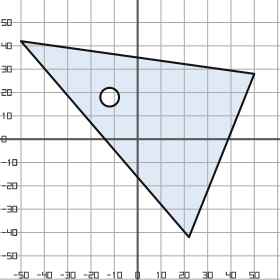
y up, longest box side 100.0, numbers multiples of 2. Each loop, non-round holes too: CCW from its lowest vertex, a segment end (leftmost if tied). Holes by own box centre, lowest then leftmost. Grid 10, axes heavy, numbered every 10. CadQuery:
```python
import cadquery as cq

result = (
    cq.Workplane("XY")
    .moveTo(22.0, -42.0)
    .lineTo(50.0, 28.0)
    .lineTo(-50.0, 42.0)
    .close()
    .moveTo(-12.0, 18.0)
    .circle(4.0)
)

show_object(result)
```